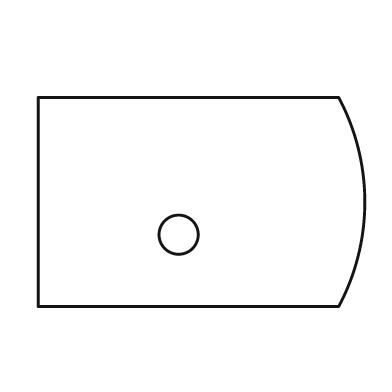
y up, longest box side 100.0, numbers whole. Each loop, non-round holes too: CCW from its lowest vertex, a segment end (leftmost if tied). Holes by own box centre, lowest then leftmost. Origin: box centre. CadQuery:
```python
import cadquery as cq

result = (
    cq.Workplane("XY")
    .moveTo(-50.0, -32.0)
    .lineTo(42.0, -32.0)
    .threePointArc((50.0, 0.0), (42.0, 32.0))
    .lineTo(-50.0, 32.0)
    .close()
    .moveTo(-7.0, -10.0)
    .circle(6.0)
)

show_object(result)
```